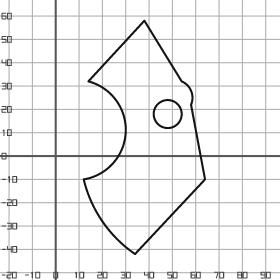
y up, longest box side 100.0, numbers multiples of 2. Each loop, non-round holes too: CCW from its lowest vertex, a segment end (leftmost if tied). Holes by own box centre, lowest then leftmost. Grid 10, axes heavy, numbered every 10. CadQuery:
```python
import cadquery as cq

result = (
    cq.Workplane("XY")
    .moveTo(34.0, -42.0)
    .lineTo(64.0, -10.0)
    .lineTo(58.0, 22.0)
    .threePointArc((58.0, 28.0), (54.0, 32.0))
    .lineTo(38.0, 58.0)
    .lineTo(14.0, 32.0)
    .threePointArc((30.0, 10.0), (12.0, -10.0))
    .threePointArc((20.0, -28.0), (34.0, -42.0))
    .close()
    .moveTo(48.0, 18.0)
    .circle(6.0)
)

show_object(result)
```